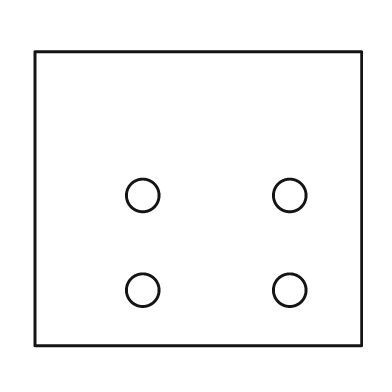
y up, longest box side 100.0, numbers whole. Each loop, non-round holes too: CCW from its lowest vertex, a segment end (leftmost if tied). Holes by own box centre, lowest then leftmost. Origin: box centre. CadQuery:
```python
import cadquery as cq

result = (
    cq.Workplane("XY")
    .moveTo(-50.0, -45.0)
    .lineTo(50.0, -45.0)
    .lineTo(50.0, 45.0)
    .lineTo(-50.0, 45.0)
    .close()
    .moveTo(-17.0, -28.0)
    .circle(5.0)
    .moveTo(28.0, -28.0)
    .circle(5.0)
    .moveTo(-17.0, 1.0)
    .circle(5.0)
    .moveTo(28.0, 1.0)
    .circle(5.0)
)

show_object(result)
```